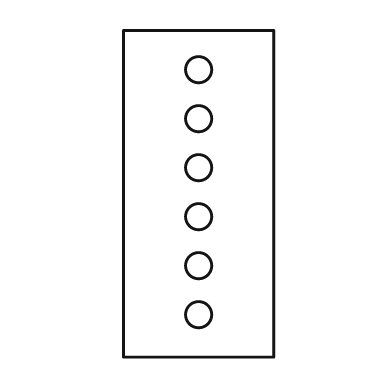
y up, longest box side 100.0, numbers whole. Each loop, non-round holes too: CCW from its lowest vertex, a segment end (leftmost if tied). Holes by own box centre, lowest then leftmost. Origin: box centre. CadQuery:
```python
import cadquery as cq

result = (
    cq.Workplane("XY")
    .moveTo(-23.0, -50.0)
    .lineTo(23.0, -50.0)
    .lineTo(23.0, 50.0)
    .lineTo(-23.0, 50.0)
    .close()
    .moveTo(0.0, -37.0)
    .circle(4.0)
    .moveTo(0.0, -22.0)
    .circle(4.0)
    .moveTo(0.0, -7.0)
    .circle(4.0)
    .moveTo(0.0, 8.0)
    .circle(4.0)
    .moveTo(0.0, 23.0)
    .circle(4.0)
    .moveTo(0.0, 38.0)
    .circle(4.0)
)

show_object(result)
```